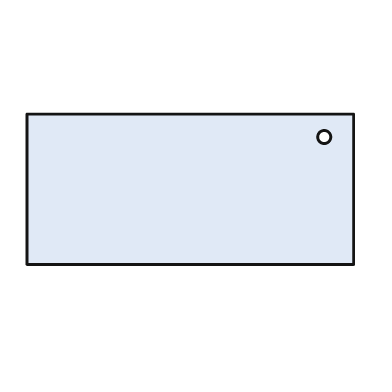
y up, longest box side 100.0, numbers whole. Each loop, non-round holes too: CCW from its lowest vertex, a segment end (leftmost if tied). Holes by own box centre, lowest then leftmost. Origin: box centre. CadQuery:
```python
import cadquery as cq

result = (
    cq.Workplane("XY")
    .moveTo(-50.0, -23.0)
    .lineTo(50.0, -23.0)
    .lineTo(50.0, 23.0)
    .lineTo(-50.0, 23.0)
    .close()
    .moveTo(41.0, 16.0)
    .circle(2.0)
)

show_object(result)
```